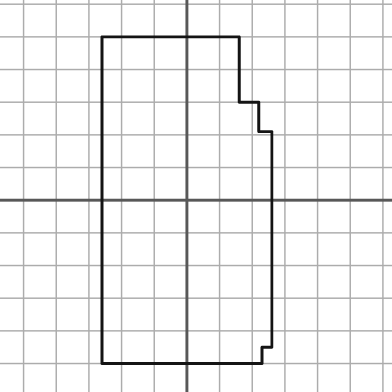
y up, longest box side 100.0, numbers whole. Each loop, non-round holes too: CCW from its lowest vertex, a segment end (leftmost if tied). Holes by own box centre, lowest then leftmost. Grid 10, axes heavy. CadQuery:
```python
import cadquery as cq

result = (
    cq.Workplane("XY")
    .moveTo(-26.0, -50.0)
    .lineTo(23.0, -50.0)
    .lineTo(23.0, -45.0)
    .lineTo(26.0, -45.0)
    .lineTo(26.0, 21.0)
    .lineTo(22.0, 21.0)
    .lineTo(22.0, 30.0)
    .lineTo(16.0, 30.0)
    .lineTo(16.0, 50.0)
    .lineTo(-26.0, 50.0)
    .close()
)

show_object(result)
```